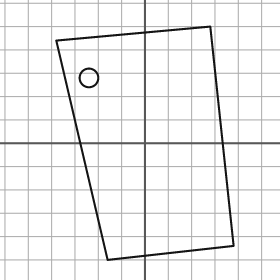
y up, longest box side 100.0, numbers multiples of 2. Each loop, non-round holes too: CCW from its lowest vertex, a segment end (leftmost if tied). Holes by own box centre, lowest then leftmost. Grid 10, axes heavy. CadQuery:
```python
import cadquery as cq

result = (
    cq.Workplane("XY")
    .moveTo(-16.0, -50.0)
    .lineTo(38.0, -44.0)
    .lineTo(28.0, 50.0)
    .lineTo(-38.0, 44.0)
    .close()
    .moveTo(-24.0, 28.0)
    .circle(4.0)
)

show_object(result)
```